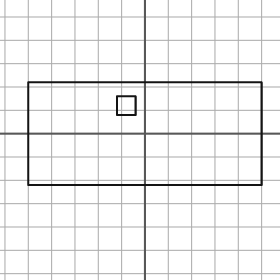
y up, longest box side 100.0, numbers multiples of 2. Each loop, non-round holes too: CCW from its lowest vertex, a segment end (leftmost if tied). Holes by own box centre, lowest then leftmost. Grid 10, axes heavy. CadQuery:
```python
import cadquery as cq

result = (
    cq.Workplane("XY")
    .moveTo(-50.0, -22.0)
    .lineTo(50.0, -22.0)
    .lineTo(50.0, 22.0)
    .lineTo(-50.0, 22.0)
    .close()
    .moveTo(-12.0, 8.0)
    .lineTo(-4.0, 8.0)
    .lineTo(-4.0, 16.0)
    .lineTo(-12.0, 16.0)
    .close()
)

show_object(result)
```